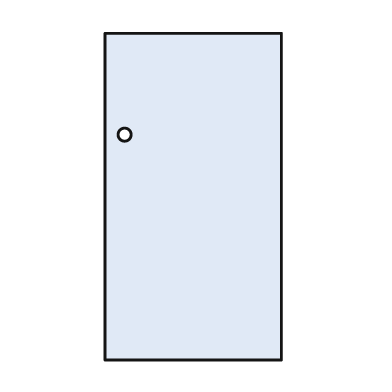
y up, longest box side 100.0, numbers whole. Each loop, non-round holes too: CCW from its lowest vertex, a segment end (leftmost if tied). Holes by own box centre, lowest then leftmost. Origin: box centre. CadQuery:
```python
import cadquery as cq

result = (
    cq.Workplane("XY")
    .moveTo(-27.0, -50.0)
    .lineTo(27.0, -50.0)
    .lineTo(27.0, 50.0)
    .lineTo(-27.0, 50.0)
    .close()
    .moveTo(-21.0, 19.0)
    .circle(2.0)
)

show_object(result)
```